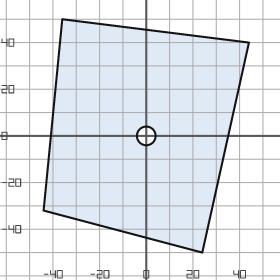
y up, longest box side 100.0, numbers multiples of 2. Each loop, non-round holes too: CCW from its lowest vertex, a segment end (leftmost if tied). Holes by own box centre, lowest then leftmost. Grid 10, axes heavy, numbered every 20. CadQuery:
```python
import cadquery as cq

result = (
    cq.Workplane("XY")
    .moveTo(24.0, -50.0)
    .lineTo(44.0, 40.0)
    .lineTo(-36.0, 50.0)
    .lineTo(-44.0, -32.0)
    .close()
    .moveTo(0.0, 0.0)
    .circle(4.0)
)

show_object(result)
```